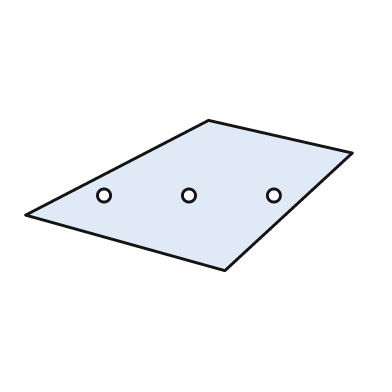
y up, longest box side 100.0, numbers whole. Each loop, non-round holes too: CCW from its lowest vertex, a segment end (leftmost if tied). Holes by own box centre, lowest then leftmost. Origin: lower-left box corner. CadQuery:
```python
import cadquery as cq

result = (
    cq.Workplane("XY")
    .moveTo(61.0, 0.0)
    .lineTo(100.0, 36.0)
    .lineTo(56.0, 46.0)
    .lineTo(0.0, 17.0)
    .close()
    .moveTo(24.0, 23.0)
    .circle(2.0)
    .moveTo(50.0, 23.0)
    .circle(2.0)
    .moveTo(76.0, 23.0)
    .circle(2.0)
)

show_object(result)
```